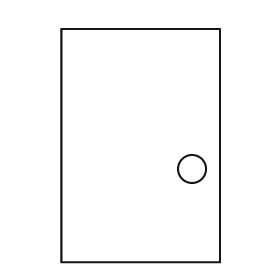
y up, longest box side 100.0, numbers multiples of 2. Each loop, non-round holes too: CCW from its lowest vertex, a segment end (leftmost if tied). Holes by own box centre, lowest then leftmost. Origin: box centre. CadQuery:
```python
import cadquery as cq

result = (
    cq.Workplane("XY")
    .moveTo(-34.0, -50.0)
    .lineTo(34.0, -50.0)
    .lineTo(34.0, 50.0)
    .lineTo(-34.0, 50.0)
    .close()
    .moveTo(22.0, -10.0)
    .circle(6.0)
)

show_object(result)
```